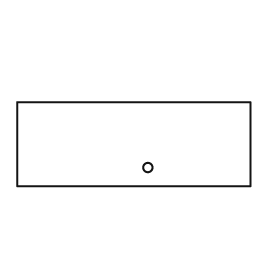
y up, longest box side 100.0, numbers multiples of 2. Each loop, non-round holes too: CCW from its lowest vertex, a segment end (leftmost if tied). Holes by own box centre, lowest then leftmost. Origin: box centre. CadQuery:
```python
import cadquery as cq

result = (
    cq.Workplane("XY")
    .moveTo(-50.0, -18.0)
    .lineTo(50.0, -18.0)
    .lineTo(50.0, 18.0)
    .lineTo(-50.0, 18.0)
    .close()
    .moveTo(6.0, -10.0)
    .circle(2.0)
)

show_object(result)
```